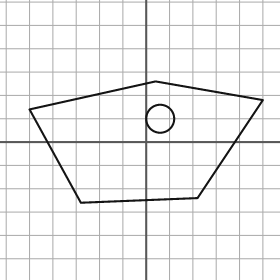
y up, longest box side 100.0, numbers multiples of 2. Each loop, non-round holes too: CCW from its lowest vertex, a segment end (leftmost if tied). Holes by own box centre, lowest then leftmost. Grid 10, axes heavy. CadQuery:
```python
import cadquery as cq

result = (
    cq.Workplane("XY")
    .moveTo(-28.0, -26.0)
    .lineTo(22.0, -24.0)
    .lineTo(50.0, 18.0)
    .lineTo(4.0, 26.0)
    .lineTo(-50.0, 14.0)
    .close()
    .moveTo(6.0, 10.0)
    .circle(6.0)
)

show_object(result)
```